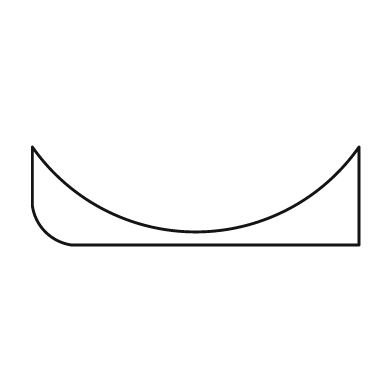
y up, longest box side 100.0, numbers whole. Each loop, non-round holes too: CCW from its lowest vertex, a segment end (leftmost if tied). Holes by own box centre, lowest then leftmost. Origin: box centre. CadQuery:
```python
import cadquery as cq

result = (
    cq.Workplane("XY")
    .moveTo(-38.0, -15.0)
    .lineTo(50.0, -15.0)
    .lineTo(50.0, 15.0)
    .threePointArc((0.0, -11.0), (-50.0, 15.0))
    .lineTo(-50.0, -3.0)
    .threePointArc((-46.0, -11.0), (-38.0, -15.0))
    .close()
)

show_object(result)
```